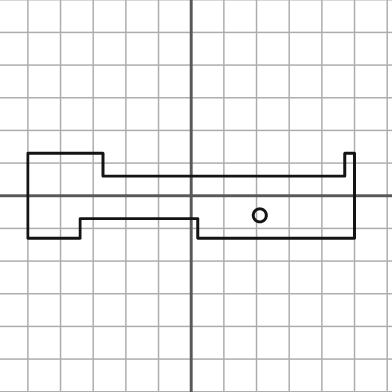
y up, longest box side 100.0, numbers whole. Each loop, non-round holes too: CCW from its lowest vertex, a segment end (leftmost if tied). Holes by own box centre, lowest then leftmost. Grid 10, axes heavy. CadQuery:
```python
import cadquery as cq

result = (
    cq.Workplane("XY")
    .moveTo(-50.0, -13.0)
    .lineTo(-34.0, -13.0)
    .lineTo(-34.0, -7.0)
    .lineTo(2.0, -7.0)
    .lineTo(2.0, -13.0)
    .lineTo(50.0, -13.0)
    .lineTo(50.0, 13.0)
    .lineTo(47.0, 13.0)
    .lineTo(47.0, 6.0)
    .lineTo(-27.0, 6.0)
    .lineTo(-27.0, 13.0)
    .lineTo(-50.0, 13.0)
    .close()
    .moveTo(21.0, -6.0)
    .circle(2.0)
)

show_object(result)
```